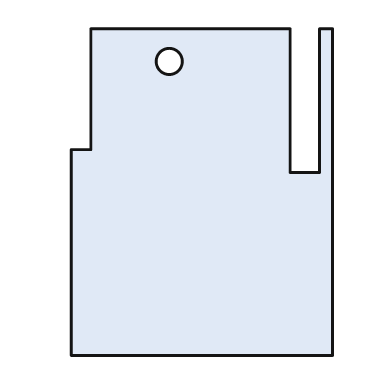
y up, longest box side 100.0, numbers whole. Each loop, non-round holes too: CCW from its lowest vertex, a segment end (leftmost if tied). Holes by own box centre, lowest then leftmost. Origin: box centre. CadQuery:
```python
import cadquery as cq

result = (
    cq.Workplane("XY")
    .moveTo(-40.0, -50.0)
    .lineTo(40.0, -50.0)
    .lineTo(40.0, 50.0)
    .lineTo(36.0, 50.0)
    .lineTo(36.0, 6.0)
    .lineTo(27.0, 6.0)
    .lineTo(27.0, 50.0)
    .lineTo(-34.0, 50.0)
    .lineTo(-34.0, 13.0)
    .lineTo(-40.0, 13.0)
    .close()
    .moveTo(-10.0, 40.0)
    .circle(4.0)
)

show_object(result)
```